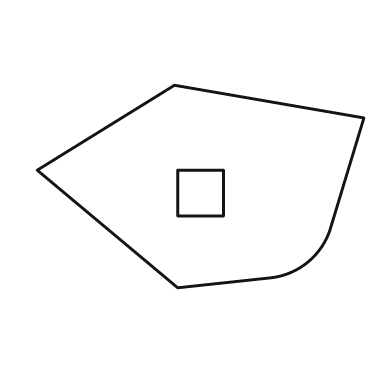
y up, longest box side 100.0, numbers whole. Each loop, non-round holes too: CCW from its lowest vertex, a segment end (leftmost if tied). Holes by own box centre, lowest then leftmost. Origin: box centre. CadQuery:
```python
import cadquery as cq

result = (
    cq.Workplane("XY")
    .moveTo(-7.0, -31.0)
    .lineTo(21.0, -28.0)
    .threePointArc((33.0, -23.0), (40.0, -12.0))
    .lineTo(50.0, 21.0)
    .lineTo(-8.0, 31.0)
    .lineTo(-50.0, 5.0)
    .close()
    .moveTo(-7.0, -9.0)
    .lineTo(7.0, -9.0)
    .lineTo(7.0, 5.0)
    .lineTo(-7.0, 5.0)
    .close()
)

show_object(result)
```